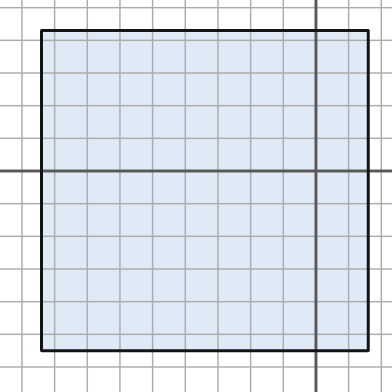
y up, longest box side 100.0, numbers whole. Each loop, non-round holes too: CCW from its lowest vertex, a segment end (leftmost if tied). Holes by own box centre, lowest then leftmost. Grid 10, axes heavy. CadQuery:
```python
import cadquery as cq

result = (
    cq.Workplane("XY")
    .moveTo(-84.0, -55.0)
    .lineTo(16.0, -55.0)
    .lineTo(16.0, 43.0)
    .lineTo(-84.0, 43.0)
    .close()
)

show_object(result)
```